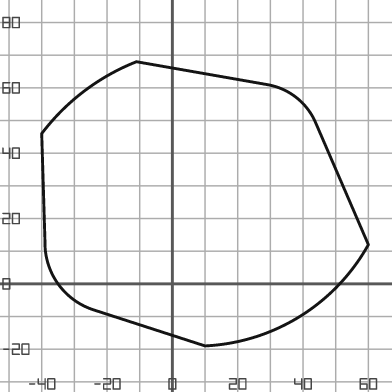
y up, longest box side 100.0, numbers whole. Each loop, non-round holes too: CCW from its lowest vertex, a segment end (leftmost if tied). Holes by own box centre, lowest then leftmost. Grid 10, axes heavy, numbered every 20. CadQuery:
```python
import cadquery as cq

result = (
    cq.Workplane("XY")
    .moveTo(10.0, -19.0)
    .threePointArc((39.0, -10.0), (60.0, 12.0))
    .lineTo(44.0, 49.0)
    .threePointArc((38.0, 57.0), (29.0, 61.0))
    .lineTo(-11.0, 68.0)
    .threePointArc((-27.0, 59.0), (-40.0, 46.0))
    .lineTo(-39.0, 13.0)
    .threePointArc((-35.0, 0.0), (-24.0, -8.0))
    .close()
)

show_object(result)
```